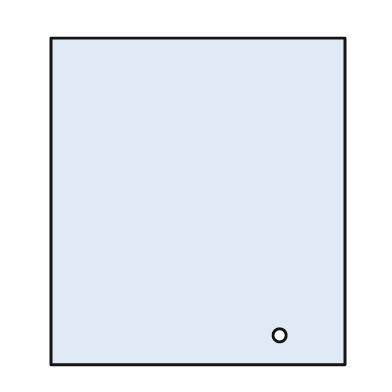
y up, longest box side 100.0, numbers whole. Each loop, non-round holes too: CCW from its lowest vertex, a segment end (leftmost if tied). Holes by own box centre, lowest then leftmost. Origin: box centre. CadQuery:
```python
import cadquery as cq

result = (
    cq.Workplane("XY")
    .moveTo(-45.0, -50.0)
    .lineTo(45.0, -50.0)
    .lineTo(45.0, 50.0)
    .lineTo(-45.0, 50.0)
    .close()
    .moveTo(25.0, -41.0)
    .circle(2.0)
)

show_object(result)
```